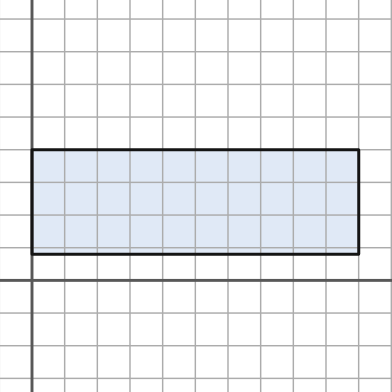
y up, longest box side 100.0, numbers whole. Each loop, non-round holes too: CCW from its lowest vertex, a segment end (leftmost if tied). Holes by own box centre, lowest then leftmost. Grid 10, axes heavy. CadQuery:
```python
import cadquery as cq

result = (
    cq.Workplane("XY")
    .moveTo(0.0, 8.0)
    .lineTo(100.0, 8.0)
    .lineTo(100.0, 40.0)
    .lineTo(0.0, 40.0)
    .close()
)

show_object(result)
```